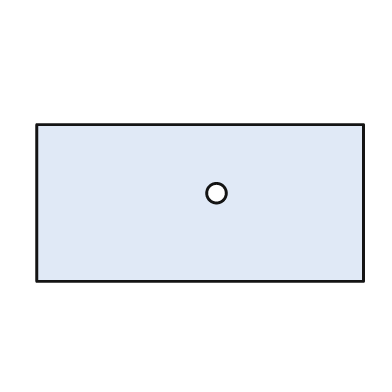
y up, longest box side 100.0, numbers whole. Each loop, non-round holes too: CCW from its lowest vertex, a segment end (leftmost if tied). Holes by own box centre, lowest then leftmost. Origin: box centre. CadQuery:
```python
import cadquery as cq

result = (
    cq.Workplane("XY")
    .moveTo(-50.0, -24.0)
    .lineTo(50.0, -24.0)
    .lineTo(50.0, 24.0)
    .lineTo(-50.0, 24.0)
    .close()
    .moveTo(5.0, 3.0)
    .circle(3.0)
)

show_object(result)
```